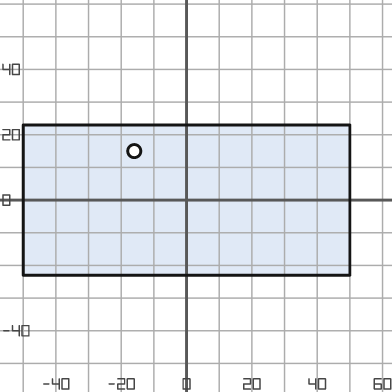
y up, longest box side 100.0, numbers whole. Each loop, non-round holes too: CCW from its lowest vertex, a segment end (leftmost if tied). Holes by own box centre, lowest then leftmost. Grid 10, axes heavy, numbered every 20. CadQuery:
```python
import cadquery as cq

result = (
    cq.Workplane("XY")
    .moveTo(-50.0, -23.0)
    .lineTo(50.0, -23.0)
    .lineTo(50.0, 23.0)
    .lineTo(-50.0, 23.0)
    .close()
    .moveTo(-16.0, 15.0)
    .circle(2.0)
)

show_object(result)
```